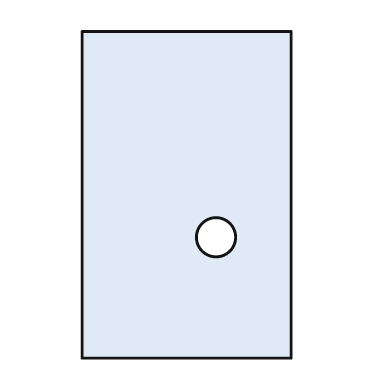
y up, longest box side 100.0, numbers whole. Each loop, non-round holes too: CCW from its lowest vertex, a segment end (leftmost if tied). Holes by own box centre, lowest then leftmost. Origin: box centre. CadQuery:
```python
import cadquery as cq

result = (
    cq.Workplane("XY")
    .moveTo(-32.0, -50.0)
    .lineTo(32.0, -50.0)
    .lineTo(32.0, 50.0)
    .lineTo(-32.0, 50.0)
    .close()
    .moveTo(9.0, -13.0)
    .circle(6.0)
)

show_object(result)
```